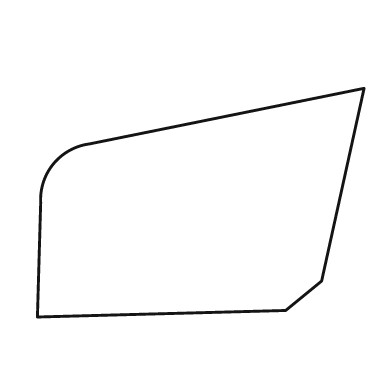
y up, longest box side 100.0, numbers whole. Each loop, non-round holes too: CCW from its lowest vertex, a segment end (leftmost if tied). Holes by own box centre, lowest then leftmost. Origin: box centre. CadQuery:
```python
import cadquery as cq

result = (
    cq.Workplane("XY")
    .moveTo(-50.0, -35.0)
    .lineTo(26.0, -33.0)
    .lineTo(37.0, -24.0)
    .lineTo(50.0, 35.0)
    .lineTo(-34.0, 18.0)
    .threePointArc((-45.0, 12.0), (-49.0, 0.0))
    .close()
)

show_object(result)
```